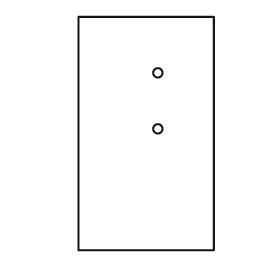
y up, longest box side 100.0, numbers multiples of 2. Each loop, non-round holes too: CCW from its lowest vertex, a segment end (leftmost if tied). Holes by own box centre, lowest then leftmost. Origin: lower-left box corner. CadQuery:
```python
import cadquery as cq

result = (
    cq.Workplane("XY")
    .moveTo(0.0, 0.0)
    .lineTo(58.0, 0.0)
    .lineTo(58.0, 100.0)
    .lineTo(0.0, 100.0)
    .close()
    .moveTo(34.0, 52.0)
    .circle(2.0)
    .moveTo(34.0, 76.0)
    .circle(2.0)
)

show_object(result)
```